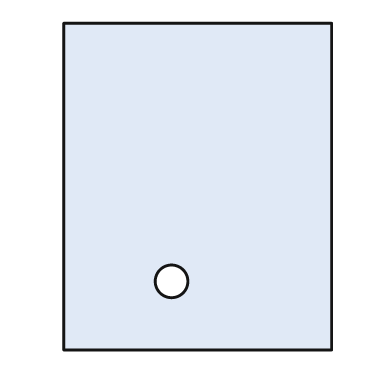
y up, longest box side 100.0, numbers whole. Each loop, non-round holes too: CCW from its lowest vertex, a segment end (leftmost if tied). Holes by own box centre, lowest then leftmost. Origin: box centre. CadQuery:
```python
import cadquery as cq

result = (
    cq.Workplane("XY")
    .moveTo(-41.0, -50.0)
    .lineTo(41.0, -50.0)
    .lineTo(41.0, 50.0)
    .lineTo(-41.0, 50.0)
    .close()
    .moveTo(-8.0, -29.0)
    .circle(5.0)
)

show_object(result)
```